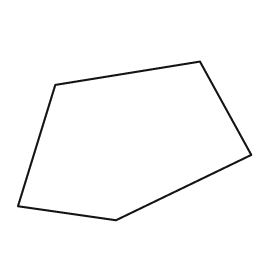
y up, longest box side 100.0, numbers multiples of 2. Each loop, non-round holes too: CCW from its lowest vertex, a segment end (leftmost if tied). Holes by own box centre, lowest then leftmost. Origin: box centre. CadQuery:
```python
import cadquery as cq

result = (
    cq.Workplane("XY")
    .moveTo(-8.0, -34.0)
    .lineTo(50.0, -6.0)
    .lineTo(28.0, 34.0)
    .lineTo(-34.0, 24.0)
    .lineTo(-50.0, -28.0)
    .close()
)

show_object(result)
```